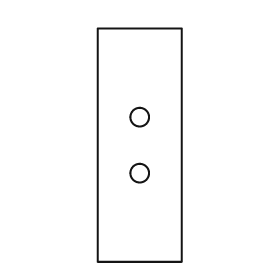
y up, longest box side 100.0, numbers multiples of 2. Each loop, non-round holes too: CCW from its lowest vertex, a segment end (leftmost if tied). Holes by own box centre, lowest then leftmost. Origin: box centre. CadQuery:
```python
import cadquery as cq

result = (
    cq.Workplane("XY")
    .moveTo(-18.0, -50.0)
    .lineTo(18.0, -50.0)
    .lineTo(18.0, 50.0)
    .lineTo(-18.0, 50.0)
    .close()
    .moveTo(0.0, -12.0)
    .circle(4.0)
    .moveTo(0.0, 12.0)
    .circle(4.0)
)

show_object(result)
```